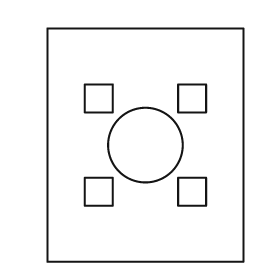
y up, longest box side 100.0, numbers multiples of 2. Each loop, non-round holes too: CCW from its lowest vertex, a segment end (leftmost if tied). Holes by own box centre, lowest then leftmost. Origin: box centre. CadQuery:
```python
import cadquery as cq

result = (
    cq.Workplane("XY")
    .moveTo(-42.0, -50.0)
    .lineTo(42.0, -50.0)
    .lineTo(42.0, 50.0)
    .lineTo(-42.0, 50.0)
    .close()
    .moveTo(-26.0, -26.0)
    .lineTo(-14.0, -26.0)
    .lineTo(-14.0, -14.0)
    .lineTo(-26.0, -14.0)
    .close()
    .moveTo(14.0, -26.0)
    .lineTo(26.0, -26.0)
    .lineTo(26.0, -14.0)
    .lineTo(14.0, -14.0)
    .close()
    .moveTo(0.0, 0.0)
    .circle(16.0)
    .moveTo(-26.0, 14.0)
    .lineTo(-14.0, 14.0)
    .lineTo(-14.0, 26.0)
    .lineTo(-26.0, 26.0)
    .close()
    .moveTo(14.0, 14.0)
    .lineTo(26.0, 14.0)
    .lineTo(26.0, 26.0)
    .lineTo(14.0, 26.0)
    .close()
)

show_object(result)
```